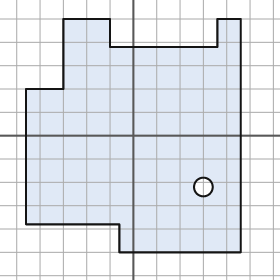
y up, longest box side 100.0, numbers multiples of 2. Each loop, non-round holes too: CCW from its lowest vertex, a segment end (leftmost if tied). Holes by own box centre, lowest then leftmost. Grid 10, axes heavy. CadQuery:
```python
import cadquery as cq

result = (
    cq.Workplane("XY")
    .moveTo(-6.0, -50.0)
    .lineTo(46.0, -50.0)
    .lineTo(46.0, 50.0)
    .lineTo(36.0, 50.0)
    .lineTo(36.0, 38.0)
    .lineTo(-10.0, 38.0)
    .lineTo(-10.0, 50.0)
    .lineTo(-30.0, 50.0)
    .lineTo(-30.0, 20.0)
    .lineTo(-46.0, 20.0)
    .lineTo(-46.0, -38.0)
    .lineTo(-6.0, -38.0)
    .close()
    .moveTo(30.0, -22.0)
    .circle(4.0)
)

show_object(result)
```